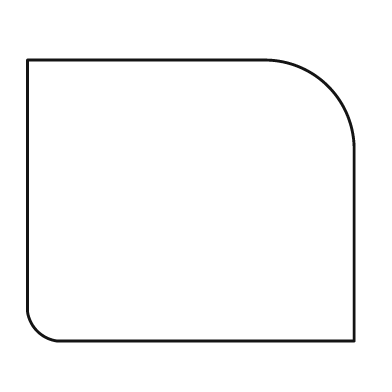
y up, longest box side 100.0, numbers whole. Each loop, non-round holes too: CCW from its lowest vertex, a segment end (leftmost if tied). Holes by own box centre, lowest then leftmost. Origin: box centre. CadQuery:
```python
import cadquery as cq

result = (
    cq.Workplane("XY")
    .moveTo(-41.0, -43.0)
    .lineTo(50.0, -43.0)
    .lineTo(50.0, 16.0)
    .threePointArc((42.0, 35.0), (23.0, 43.0))
    .lineTo(-50.0, 43.0)
    .lineTo(-50.0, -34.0)
    .threePointArc((-47.0, -40.0), (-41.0, -43.0))
    .close()
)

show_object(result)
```